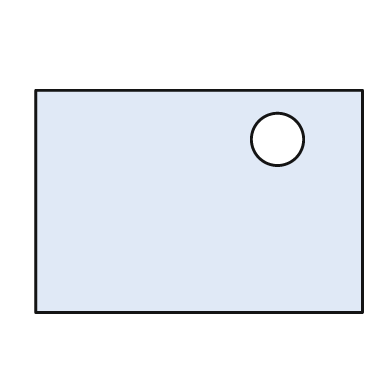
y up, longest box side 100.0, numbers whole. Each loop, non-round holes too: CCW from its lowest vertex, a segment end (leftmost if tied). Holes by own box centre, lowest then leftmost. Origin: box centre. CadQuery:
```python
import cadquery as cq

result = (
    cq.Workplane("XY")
    .moveTo(-50.0, -34.0)
    .lineTo(50.0, -34.0)
    .lineTo(50.0, 34.0)
    .lineTo(-50.0, 34.0)
    .close()
    .moveTo(24.0, 19.0)
    .circle(8.0)
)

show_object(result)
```